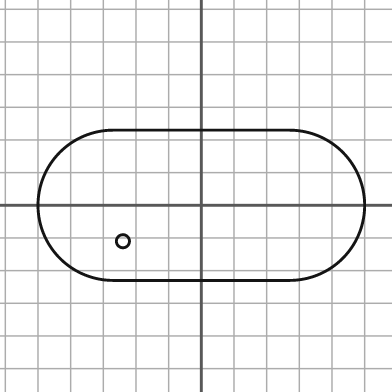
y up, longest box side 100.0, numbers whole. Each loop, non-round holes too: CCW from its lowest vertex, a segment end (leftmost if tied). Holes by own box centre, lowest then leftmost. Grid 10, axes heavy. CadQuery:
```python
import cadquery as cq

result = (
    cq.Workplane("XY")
    .moveTo(-27.0, -23.0)
    .lineTo(27.0, -23.0)
    .threePointArc((50.0, 0.0), (27.0, 23.0))
    .lineTo(-27.0, 23.0)
    .threePointArc((-50.0, 0.0), (-27.0, -23.0))
    .close()
    .moveTo(-24.0, -11.0)
    .circle(2.0)
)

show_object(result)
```